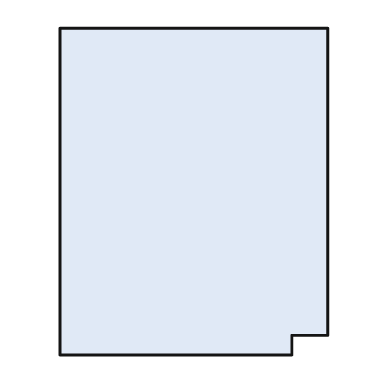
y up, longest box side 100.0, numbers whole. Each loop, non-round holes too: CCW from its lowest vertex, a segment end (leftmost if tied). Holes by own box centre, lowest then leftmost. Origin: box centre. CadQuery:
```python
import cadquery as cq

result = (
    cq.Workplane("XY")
    .moveTo(-41.0, -50.0)
    .lineTo(30.0, -50.0)
    .lineTo(30.0, -44.0)
    .lineTo(41.0, -44.0)
    .lineTo(41.0, 50.0)
    .lineTo(-41.0, 50.0)
    .close()
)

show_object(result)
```